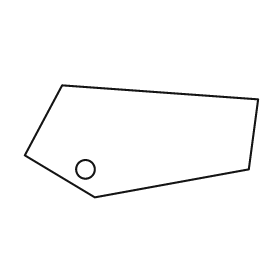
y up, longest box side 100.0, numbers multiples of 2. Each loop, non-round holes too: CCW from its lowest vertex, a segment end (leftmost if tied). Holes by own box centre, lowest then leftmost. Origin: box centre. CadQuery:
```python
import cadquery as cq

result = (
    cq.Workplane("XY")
    .moveTo(-20.0, -24.0)
    .lineTo(46.0, -12.0)
    .lineTo(50.0, 18.0)
    .lineTo(-34.0, 24.0)
    .lineTo(-50.0, -6.0)
    .close()
    .moveTo(-24.0, -12.0)
    .circle(4.0)
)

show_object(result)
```